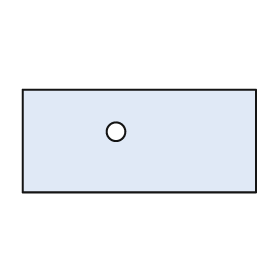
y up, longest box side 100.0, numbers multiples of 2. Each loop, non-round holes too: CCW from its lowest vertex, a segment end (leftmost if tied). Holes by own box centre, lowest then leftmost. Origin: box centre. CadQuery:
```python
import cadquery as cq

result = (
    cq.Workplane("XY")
    .moveTo(-50.0, -22.0)
    .lineTo(50.0, -22.0)
    .lineTo(50.0, 22.0)
    .lineTo(-50.0, 22.0)
    .close()
    .moveTo(-10.0, 4.0)
    .circle(4.0)
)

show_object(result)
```